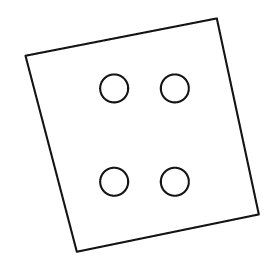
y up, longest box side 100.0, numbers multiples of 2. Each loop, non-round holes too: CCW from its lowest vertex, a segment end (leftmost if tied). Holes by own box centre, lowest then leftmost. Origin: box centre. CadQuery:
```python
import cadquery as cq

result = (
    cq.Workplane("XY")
    .moveTo(-28.0, -50.0)
    .lineTo(50.0, -34.0)
    .lineTo(32.0, 50.0)
    .lineTo(-50.0, 34.0)
    .close()
    .moveTo(-12.0, -20.0)
    .circle(6.0)
    .moveTo(14.0, -20.0)
    .circle(6.0)
    .moveTo(-12.0, 20.0)
    .circle(6.0)
    .moveTo(14.0, 20.0)
    .circle(6.0)
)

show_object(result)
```